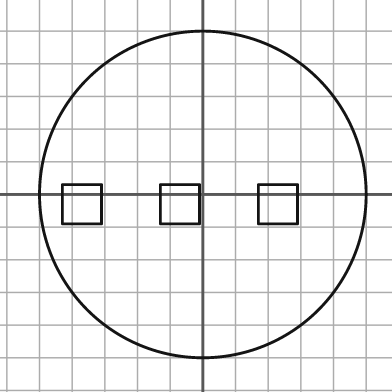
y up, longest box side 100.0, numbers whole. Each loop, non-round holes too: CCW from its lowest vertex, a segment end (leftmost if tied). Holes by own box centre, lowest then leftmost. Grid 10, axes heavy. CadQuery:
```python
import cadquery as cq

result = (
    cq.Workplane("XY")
    .moveTo(0.0, 0.0)
    .circle(50.0)
    .moveTo(-43.0, -9.0)
    .lineTo(-31.0, -9.0)
    .lineTo(-31.0, 3.0)
    .lineTo(-43.0, 3.0)
    .close()
    .moveTo(-13.0, -9.0)
    .lineTo(-1.0, -9.0)
    .lineTo(-1.0, 3.0)
    .lineTo(-13.0, 3.0)
    .close()
    .moveTo(17.0, -9.0)
    .lineTo(29.0, -9.0)
    .lineTo(29.0, 3.0)
    .lineTo(17.0, 3.0)
    .close()
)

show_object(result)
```